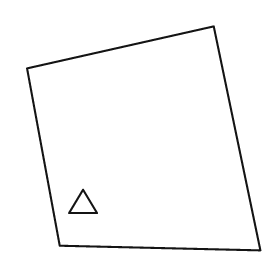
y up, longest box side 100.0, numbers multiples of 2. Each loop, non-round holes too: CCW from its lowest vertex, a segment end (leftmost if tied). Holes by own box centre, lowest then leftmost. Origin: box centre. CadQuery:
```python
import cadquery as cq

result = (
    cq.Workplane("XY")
    .moveTo(50.0, -48.0)
    .lineTo(30.0, 48.0)
    .lineTo(-50.0, 30.0)
    .lineTo(-36.0, -46.0)
    .close()
    .moveTo(-32.0, -32.0)
    .lineTo(-20.0, -32.0)
    .lineTo(-26.0, -22.0)
    .close()
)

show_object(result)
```